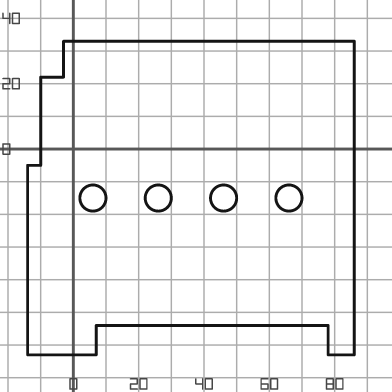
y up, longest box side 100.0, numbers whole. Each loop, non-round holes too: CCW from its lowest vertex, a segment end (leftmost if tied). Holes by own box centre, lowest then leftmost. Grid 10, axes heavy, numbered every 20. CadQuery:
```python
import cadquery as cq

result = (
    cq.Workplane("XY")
    .moveTo(-14.0, -63.0)
    .lineTo(7.0, -63.0)
    .lineTo(7.0, -54.0)
    .lineTo(78.0, -54.0)
    .lineTo(78.0, -63.0)
    .lineTo(86.0, -63.0)
    .lineTo(86.0, 33.0)
    .lineTo(-3.0, 33.0)
    .lineTo(-3.0, 22.0)
    .lineTo(-10.0, 22.0)
    .lineTo(-10.0, -5.0)
    .lineTo(-14.0, -5.0)
    .close()
    .moveTo(6.0, -15.0)
    .circle(4.0)
    .moveTo(26.0, -15.0)
    .circle(4.0)
    .moveTo(46.0, -15.0)
    .circle(4.0)
    .moveTo(66.0, -15.0)
    .circle(4.0)
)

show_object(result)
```